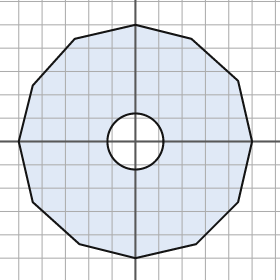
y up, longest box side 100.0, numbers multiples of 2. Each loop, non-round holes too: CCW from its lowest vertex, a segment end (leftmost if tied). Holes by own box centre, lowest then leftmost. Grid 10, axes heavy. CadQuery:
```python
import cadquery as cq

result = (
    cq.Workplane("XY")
    .moveTo(0.0, -50.0)
    .lineTo(26.0, -44.0)
    .lineTo(44.0, -26.0)
    .lineTo(50.0, 0.0)
    .lineTo(44.0, 26.0)
    .lineTo(24.0, 44.0)
    .lineTo(0.0, 50.0)
    .lineTo(-26.0, 44.0)
    .lineTo(-44.0, 24.0)
    .lineTo(-50.0, 0.0)
    .lineTo(-44.0, -26.0)
    .lineTo(-24.0, -44.0)
    .close()
    .moveTo(0.0, 0.0)
    .circle(12.0)
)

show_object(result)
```